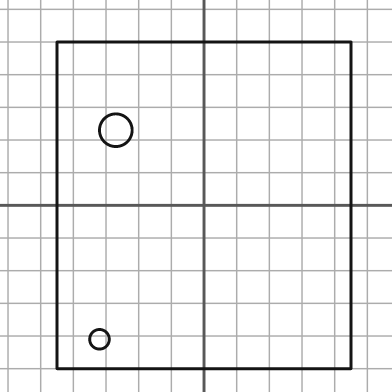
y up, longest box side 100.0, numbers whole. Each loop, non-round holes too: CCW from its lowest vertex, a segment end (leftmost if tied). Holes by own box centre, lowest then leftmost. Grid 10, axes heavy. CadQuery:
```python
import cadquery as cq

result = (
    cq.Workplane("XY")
    .moveTo(-45.0, -50.0)
    .lineTo(45.0, -50.0)
    .lineTo(45.0, 50.0)
    .lineTo(-45.0, 50.0)
    .close()
    .moveTo(-32.0, -41.0)
    .circle(3.0)
    .moveTo(-27.0, 23.0)
    .circle(5.0)
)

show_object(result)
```